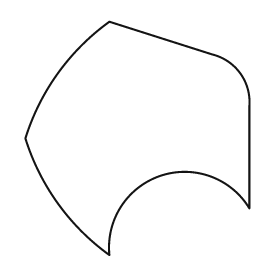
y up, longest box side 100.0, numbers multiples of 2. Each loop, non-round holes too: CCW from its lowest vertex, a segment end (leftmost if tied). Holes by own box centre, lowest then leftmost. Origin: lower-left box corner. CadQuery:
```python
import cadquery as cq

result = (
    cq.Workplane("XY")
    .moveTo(36.0, 0.0)
    .threePointArc((58.0, 34.0), (96.0, 20.0))
    .lineTo(96.0, 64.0)
    .threePointArc((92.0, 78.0), (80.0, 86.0))
    .lineTo(36.0, 100.0)
    .threePointArc((14.0, 78.0), (0.0, 50.0))
    .threePointArc((14.0, 22.0), (36.0, 0.0))
    .close()
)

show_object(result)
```